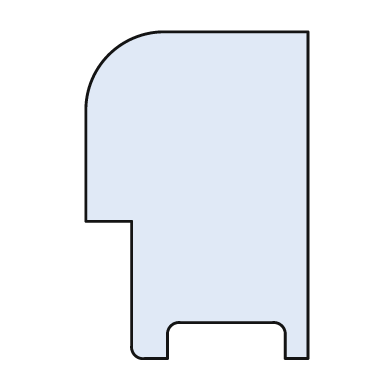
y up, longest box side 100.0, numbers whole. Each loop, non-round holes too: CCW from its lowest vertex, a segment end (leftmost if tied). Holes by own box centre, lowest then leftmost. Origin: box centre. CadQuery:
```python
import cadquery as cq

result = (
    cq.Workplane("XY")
    .moveTo(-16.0, -50.0)
    .lineTo(-9.0, -50.0)
    .lineTo(-9.0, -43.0)
    .threePointArc((-8.0, -40.0), (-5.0, -39.0))
    .lineTo(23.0, -39.0)
    .threePointArc((26.0, -40.0), (27.0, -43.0))
    .lineTo(27.0, -50.0)
    .lineTo(34.0, -50.0)
    .lineTo(34.0, 50.0)
    .lineTo(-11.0, 50.0)
    .threePointArc((-27.0, 43.0), (-34.0, 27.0))
    .lineTo(-34.0, -8.0)
    .lineTo(-20.0, -8.0)
    .lineTo(-20.0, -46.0)
    .threePointArc((-19.0, -49.0), (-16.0, -50.0))
    .close()
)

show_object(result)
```